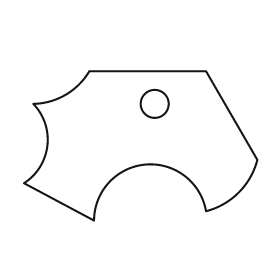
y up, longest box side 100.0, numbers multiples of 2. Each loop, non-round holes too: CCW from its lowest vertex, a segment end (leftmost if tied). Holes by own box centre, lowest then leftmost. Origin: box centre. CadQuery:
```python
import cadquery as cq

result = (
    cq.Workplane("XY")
    .moveTo(-20.0, -32.0)
    .threePointArc((2.0, -8.0), (28.0, -28.0))
    .threePointArc((42.0, -20.0), (50.0, -6.0))
    .lineTo(28.0, 32.0)
    .lineTo(-22.0, 32.0)
    .threePointArc((-32.0, 22.0), (-46.0, 18.0))
    .threePointArc((-40.0, 0.0), (-50.0, -16.0))
    .close()
    .moveTo(6.0, 18.0)
    .circle(6.0)
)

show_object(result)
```